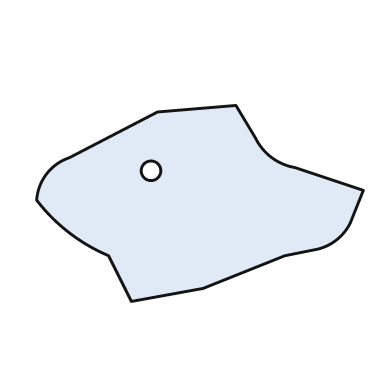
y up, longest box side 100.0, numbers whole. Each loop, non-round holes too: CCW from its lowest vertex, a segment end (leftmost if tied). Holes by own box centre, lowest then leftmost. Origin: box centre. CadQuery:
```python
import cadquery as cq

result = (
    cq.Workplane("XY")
    .moveTo(-21.0, -30.0)
    .lineTo(1.0, -26.0)
    .lineTo(26.0, -16.0)
    .lineTo(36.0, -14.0)
    .threePointArc((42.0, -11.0), (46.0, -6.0))
    .lineTo(50.0, 4.0)
    .lineTo(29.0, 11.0)
    .threePointArc((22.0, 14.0), (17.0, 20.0))
    .lineTo(11.0, 30.0)
    .lineTo(-13.0, 28.0)
    .lineTo(-40.0, 14.0)
    .threePointArc((-47.0, 9.0), (-50.0, 1.0))
    .threePointArc((-40.0, -9.0), (-28.0, -16.0))
    .close()
    .moveTo(-15.0, 10.0)
    .circle(3.0)
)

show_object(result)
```